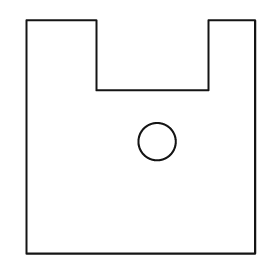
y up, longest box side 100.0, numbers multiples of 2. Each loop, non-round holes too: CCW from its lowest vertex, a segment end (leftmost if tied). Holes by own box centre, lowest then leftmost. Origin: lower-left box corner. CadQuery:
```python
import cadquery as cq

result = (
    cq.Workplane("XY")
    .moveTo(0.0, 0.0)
    .lineTo(98.0, 0.0)
    .lineTo(98.0, 100.0)
    .lineTo(78.0, 100.0)
    .lineTo(78.0, 70.0)
    .lineTo(30.0, 70.0)
    .lineTo(30.0, 100.0)
    .lineTo(0.0, 100.0)
    .close()
    .moveTo(56.0, 48.0)
    .circle(8.0)
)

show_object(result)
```